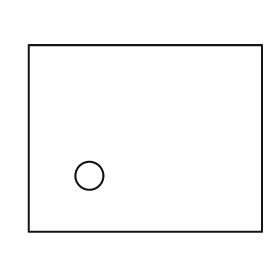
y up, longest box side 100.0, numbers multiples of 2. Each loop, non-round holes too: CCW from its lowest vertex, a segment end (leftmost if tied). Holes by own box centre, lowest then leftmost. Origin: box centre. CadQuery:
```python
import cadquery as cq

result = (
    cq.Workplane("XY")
    .moveTo(-50.0, -40.0)
    .lineTo(50.0, -40.0)
    .lineTo(50.0, 40.0)
    .lineTo(-50.0, 40.0)
    .close()
    .moveTo(-24.0, -16.0)
    .circle(6.0)
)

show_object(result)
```